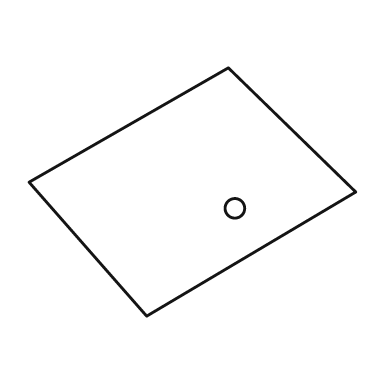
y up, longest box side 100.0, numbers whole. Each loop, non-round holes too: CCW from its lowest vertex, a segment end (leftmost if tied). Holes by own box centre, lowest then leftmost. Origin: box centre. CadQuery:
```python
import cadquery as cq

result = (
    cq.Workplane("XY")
    .moveTo(-14.0, -38.0)
    .lineTo(50.0, 0.0)
    .lineTo(11.0, 38.0)
    .lineTo(-50.0, 3.0)
    .close()
    .moveTo(13.0, -5.0)
    .circle(3.0)
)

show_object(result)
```